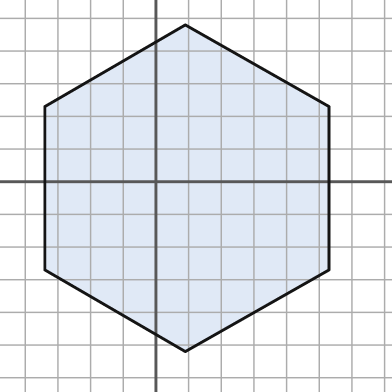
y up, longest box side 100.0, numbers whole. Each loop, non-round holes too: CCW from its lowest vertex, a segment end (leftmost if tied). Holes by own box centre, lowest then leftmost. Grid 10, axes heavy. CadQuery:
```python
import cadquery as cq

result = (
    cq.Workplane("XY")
    .moveTo(9.0, -52.0)
    .lineTo(53.0, -27.0)
    .lineTo(53.0, 23.0)
    .lineTo(9.0, 48.0)
    .lineTo(-34.0, 23.0)
    .lineTo(-34.0, -27.0)
    .close()
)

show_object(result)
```